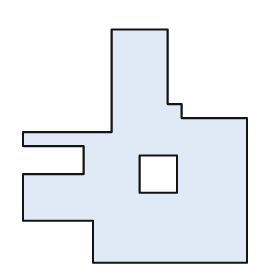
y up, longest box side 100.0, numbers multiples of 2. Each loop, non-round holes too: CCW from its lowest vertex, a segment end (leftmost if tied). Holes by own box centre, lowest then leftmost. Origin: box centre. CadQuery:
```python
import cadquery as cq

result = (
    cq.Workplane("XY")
    .moveTo(-18.0, -50.0)
    .lineTo(48.0, -50.0)
    .lineTo(48.0, 12.0)
    .lineTo(20.0, 12.0)
    .lineTo(20.0, 18.0)
    .lineTo(14.0, 18.0)
    .lineTo(14.0, 50.0)
    .lineTo(-10.0, 50.0)
    .lineTo(-10.0, 6.0)
    .lineTo(-48.0, 6.0)
    .lineTo(-48.0, 0.0)
    .lineTo(-22.0, 0.0)
    .lineTo(-22.0, -12.0)
    .lineTo(-48.0, -12.0)
    .lineTo(-48.0, -32.0)
    .lineTo(-18.0, -32.0)
    .close()
    .moveTo(2.0, -20.0)
    .lineTo(18.0, -20.0)
    .lineTo(18.0, -4.0)
    .lineTo(2.0, -4.0)
    .close()
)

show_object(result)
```